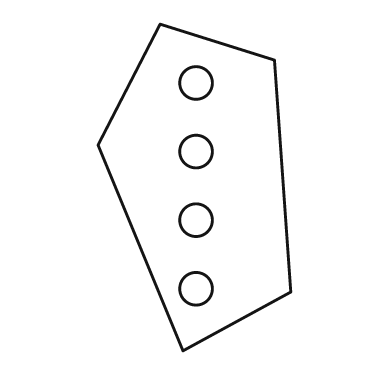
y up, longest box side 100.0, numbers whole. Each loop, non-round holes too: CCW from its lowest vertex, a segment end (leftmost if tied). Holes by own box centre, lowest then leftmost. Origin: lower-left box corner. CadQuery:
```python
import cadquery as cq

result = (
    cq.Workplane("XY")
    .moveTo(26.0, 0.0)
    .lineTo(59.0, 18.0)
    .lineTo(54.0, 89.0)
    .lineTo(19.0, 100.0)
    .lineTo(0.0, 63.0)
    .close()
    .moveTo(30.0, 19.0)
    .circle(5.0)
    .moveTo(30.0, 40.0)
    .circle(5.0)
    .moveTo(30.0, 61.0)
    .circle(5.0)
    .moveTo(30.0, 82.0)
    .circle(5.0)
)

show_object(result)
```